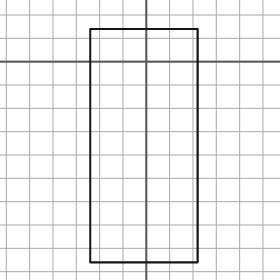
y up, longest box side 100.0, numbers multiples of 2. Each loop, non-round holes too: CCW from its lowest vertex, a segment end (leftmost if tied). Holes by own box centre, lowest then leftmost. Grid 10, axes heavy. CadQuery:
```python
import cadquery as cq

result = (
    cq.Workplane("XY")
    .moveTo(-24.0, -86.0)
    .lineTo(22.0, -86.0)
    .lineTo(22.0, 14.0)
    .lineTo(-24.0, 14.0)
    .close()
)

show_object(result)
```